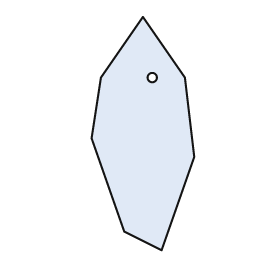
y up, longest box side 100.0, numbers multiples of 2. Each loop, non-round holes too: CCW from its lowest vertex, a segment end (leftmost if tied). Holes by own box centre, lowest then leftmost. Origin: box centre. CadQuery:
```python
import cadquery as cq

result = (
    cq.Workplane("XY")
    .moveTo(8.0, -50.0)
    .lineTo(22.0, -10.0)
    .lineTo(18.0, 24.0)
    .lineTo(0.0, 50.0)
    .lineTo(-18.0, 24.0)
    .lineTo(-22.0, -2.0)
    .lineTo(-8.0, -42.0)
    .close()
    .moveTo(4.0, 24.0)
    .circle(2.0)
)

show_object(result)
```